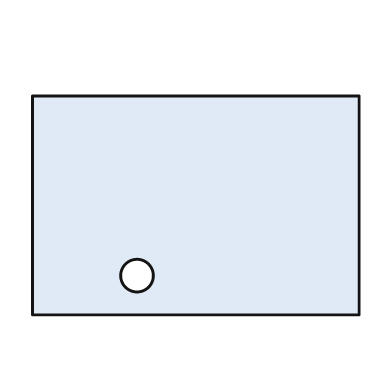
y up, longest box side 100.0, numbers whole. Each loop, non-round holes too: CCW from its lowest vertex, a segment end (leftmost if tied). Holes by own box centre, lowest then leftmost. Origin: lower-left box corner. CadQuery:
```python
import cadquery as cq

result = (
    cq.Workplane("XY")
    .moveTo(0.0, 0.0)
    .lineTo(100.0, 0.0)
    .lineTo(100.0, 67.0)
    .lineTo(0.0, 67.0)
    .close()
    .moveTo(32.0, 12.0)
    .circle(5.0)
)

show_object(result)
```